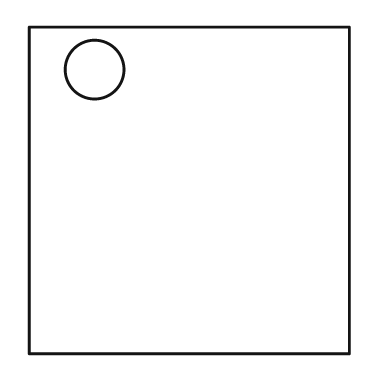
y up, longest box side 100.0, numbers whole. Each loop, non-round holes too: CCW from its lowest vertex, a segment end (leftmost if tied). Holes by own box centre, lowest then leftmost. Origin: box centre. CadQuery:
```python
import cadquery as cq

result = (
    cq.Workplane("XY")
    .moveTo(-49.0, -50.0)
    .lineTo(49.0, -50.0)
    .lineTo(49.0, 50.0)
    .lineTo(-49.0, 50.0)
    .close()
    .moveTo(-29.0, 37.0)
    .circle(9.0)
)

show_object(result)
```